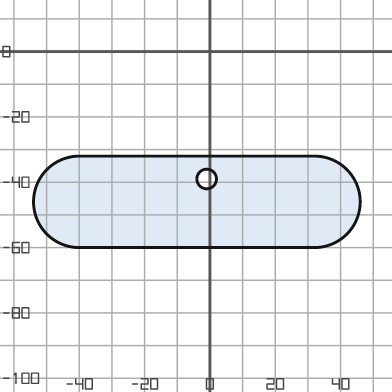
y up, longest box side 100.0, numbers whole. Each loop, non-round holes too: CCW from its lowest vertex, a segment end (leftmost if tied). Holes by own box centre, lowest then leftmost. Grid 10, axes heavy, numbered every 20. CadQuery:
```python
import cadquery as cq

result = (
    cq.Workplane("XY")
    .moveTo(-40.0, -60.0)
    .lineTo(32.0, -60.0)
    .threePointArc((46.0, -46.0), (32.0, -32.0))
    .lineTo(-40.0, -32.0)
    .threePointArc((-54.0, -46.0), (-40.0, -60.0))
    .close()
    .moveTo(-1.0, -39.0)
    .circle(3.0)
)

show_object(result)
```